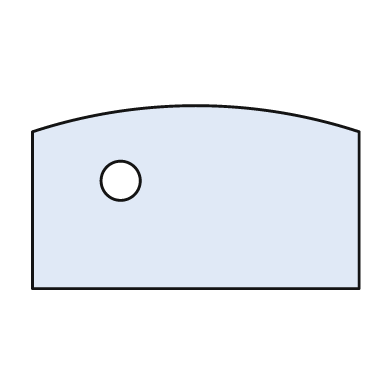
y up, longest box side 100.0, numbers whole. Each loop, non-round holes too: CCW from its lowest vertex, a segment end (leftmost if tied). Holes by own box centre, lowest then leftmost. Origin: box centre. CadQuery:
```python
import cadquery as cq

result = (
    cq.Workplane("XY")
    .moveTo(-50.0, -28.0)
    .lineTo(50.0, -28.0)
    .lineTo(50.0, 20.0)
    .threePointArc((0.0, 28.0), (-50.0, 20.0))
    .close()
    .moveTo(-23.0, 5.0)
    .circle(6.0)
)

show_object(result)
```